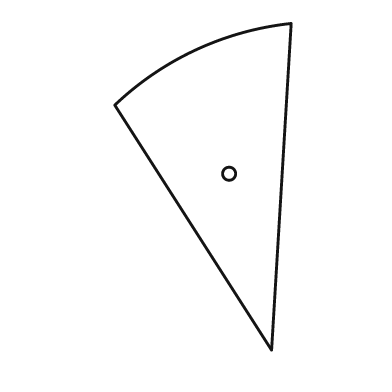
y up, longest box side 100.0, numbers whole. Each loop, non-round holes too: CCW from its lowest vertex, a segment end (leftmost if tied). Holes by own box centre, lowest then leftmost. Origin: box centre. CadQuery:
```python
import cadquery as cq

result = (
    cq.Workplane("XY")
    .moveTo(21.0, -50.0)
    .lineTo(27.0, 50.0)
    .threePointArc((-2.0, 42.0), (-27.0, 25.0))
    .close()
    .moveTo(8.0, 4.0)
    .circle(2.0)
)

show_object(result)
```